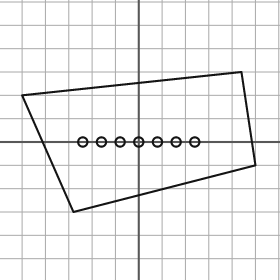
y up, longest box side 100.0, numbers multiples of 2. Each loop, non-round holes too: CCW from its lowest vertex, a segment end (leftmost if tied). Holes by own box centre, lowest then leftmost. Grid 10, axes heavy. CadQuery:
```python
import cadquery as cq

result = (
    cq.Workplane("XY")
    .moveTo(-28.0, -30.0)
    .lineTo(50.0, -10.0)
    .lineTo(44.0, 30.0)
    .lineTo(-50.0, 20.0)
    .close()
    .moveTo(-24.0, 0.0)
    .circle(2.0)
    .moveTo(-16.0, 0.0)
    .circle(2.0)
    .moveTo(-8.0, 0.0)
    .circle(2.0)
    .moveTo(0.0, 0.0)
    .circle(2.0)
    .moveTo(8.0, 0.0)
    .circle(2.0)
    .moveTo(16.0, 0.0)
    .circle(2.0)
    .moveTo(24.0, 0.0)
    .circle(2.0)
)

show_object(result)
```